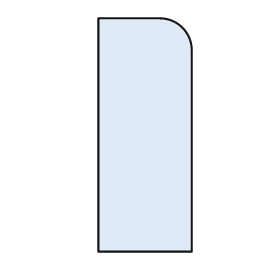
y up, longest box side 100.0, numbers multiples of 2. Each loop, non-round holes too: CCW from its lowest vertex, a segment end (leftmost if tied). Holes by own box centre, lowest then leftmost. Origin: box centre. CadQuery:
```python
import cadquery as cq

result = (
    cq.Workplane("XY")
    .moveTo(-20.0, -50.0)
    .lineTo(20.0, -50.0)
    .lineTo(20.0, 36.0)
    .threePointArc((16.0, 46.0), (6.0, 50.0))
    .lineTo(-20.0, 50.0)
    .close()
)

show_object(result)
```